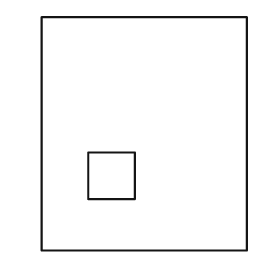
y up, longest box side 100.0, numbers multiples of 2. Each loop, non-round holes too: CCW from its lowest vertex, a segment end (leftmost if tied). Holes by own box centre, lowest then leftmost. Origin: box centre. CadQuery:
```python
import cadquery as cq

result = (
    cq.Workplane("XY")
    .moveTo(-44.0, -50.0)
    .lineTo(44.0, -50.0)
    .lineTo(44.0, 50.0)
    .lineTo(-44.0, 50.0)
    .close()
    .moveTo(-24.0, -28.0)
    .lineTo(-4.0, -28.0)
    .lineTo(-4.0, -8.0)
    .lineTo(-24.0, -8.0)
    .close()
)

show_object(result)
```